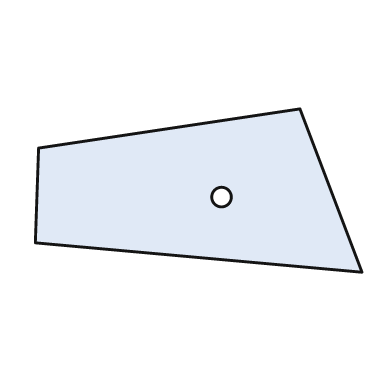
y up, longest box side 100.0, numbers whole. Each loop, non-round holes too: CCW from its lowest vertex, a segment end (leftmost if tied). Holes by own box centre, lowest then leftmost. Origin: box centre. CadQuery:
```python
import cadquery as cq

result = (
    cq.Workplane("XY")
    .moveTo(50.0, -25.0)
    .lineTo(31.0, 25.0)
    .lineTo(-49.0, 13.0)
    .lineTo(-50.0, -16.0)
    .close()
    .moveTo(7.0, -2.0)
    .circle(3.0)
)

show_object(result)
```